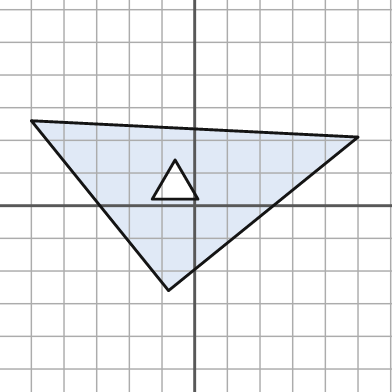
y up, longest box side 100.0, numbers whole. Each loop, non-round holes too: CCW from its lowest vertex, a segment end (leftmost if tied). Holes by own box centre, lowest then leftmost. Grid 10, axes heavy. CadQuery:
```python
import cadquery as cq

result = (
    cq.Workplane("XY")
    .moveTo(-8.0, -26.0)
    .lineTo(50.0, 21.0)
    .lineTo(-50.0, 26.0)
    .close()
    .moveTo(-13.0, 2.0)
    .lineTo(1.0, 2.0)
    .lineTo(-6.0, 14.0)
    .close()
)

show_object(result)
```